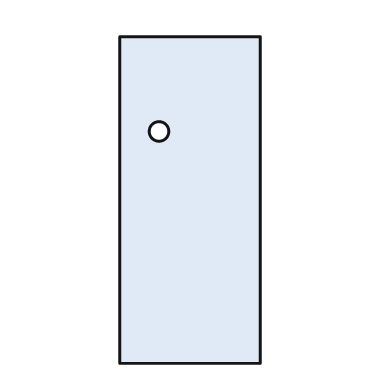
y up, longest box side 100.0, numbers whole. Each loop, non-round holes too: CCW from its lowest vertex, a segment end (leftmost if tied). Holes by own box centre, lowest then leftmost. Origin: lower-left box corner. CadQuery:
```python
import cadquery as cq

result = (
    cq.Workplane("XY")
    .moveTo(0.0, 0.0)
    .lineTo(43.0, 0.0)
    .lineTo(43.0, 100.0)
    .lineTo(0.0, 100.0)
    .close()
    .moveTo(12.0, 71.0)
    .circle(3.0)
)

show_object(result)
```